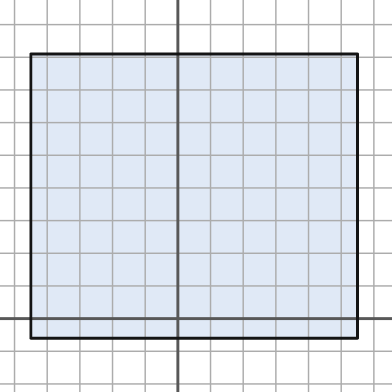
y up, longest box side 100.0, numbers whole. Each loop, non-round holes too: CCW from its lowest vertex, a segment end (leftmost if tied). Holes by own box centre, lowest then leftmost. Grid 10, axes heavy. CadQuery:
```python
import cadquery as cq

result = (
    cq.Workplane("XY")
    .moveTo(-45.0, -6.0)
    .lineTo(55.0, -6.0)
    .lineTo(55.0, 81.0)
    .lineTo(-45.0, 81.0)
    .close()
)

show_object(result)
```